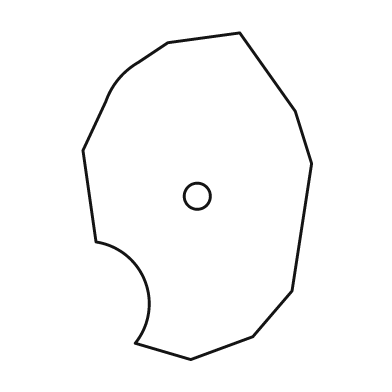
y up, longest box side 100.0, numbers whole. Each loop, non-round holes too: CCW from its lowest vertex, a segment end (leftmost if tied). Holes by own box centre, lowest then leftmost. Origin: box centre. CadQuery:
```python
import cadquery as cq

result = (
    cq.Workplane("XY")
    .moveTo(-2.0, -50.0)
    .lineTo(17.0, -43.0)
    .lineTo(29.0, -29.0)
    .lineTo(35.0, 10.0)
    .lineTo(30.0, 26.0)
    .lineTo(13.0, 50.0)
    .lineTo(-9.0, 47.0)
    .lineTo(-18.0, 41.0)
    .threePointArc((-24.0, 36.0), (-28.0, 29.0))
    .lineTo(-35.0, 14.0)
    .lineTo(-31.0, -14.0)
    .threePointArc((-16.0, -26.0), (-19.0, -45.0))
    .close()
    .moveTo(0.0, 0.0)
    .circle(4.0)
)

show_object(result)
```